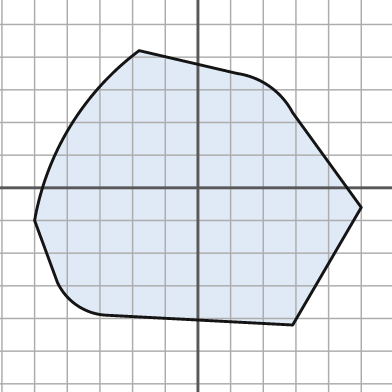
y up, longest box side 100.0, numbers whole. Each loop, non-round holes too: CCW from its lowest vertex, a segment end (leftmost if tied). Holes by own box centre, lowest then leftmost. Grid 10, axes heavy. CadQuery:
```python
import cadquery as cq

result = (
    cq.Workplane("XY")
    .moveTo(29.0, -42.0)
    .lineTo(50.0, -6.0)
    .lineTo(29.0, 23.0)
    .threePointArc((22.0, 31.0), (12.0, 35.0))
    .lineTo(-18.0, 42.0)
    .threePointArc((-39.0, 19.0), (-50.0, -10.0))
    .lineTo(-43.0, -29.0)
    .threePointArc((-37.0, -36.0), (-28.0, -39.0))
    .close()
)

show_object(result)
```